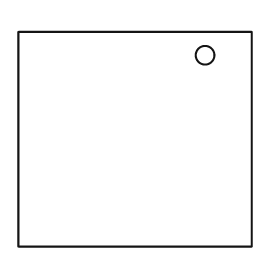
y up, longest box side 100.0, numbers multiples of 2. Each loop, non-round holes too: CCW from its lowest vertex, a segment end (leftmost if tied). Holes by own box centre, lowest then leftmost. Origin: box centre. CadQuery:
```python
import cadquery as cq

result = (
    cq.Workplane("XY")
    .moveTo(-50.0, -46.0)
    .lineTo(50.0, -46.0)
    .lineTo(50.0, 46.0)
    .lineTo(-50.0, 46.0)
    .close()
    .moveTo(30.0, 36.0)
    .circle(4.0)
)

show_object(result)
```